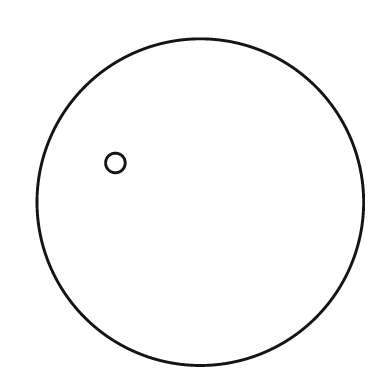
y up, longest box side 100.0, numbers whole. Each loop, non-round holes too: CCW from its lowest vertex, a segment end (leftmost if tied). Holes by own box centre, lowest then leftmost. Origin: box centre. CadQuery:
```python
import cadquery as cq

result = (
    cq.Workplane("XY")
    .moveTo(0.0, 0.0)
    .circle(50.0)
    .moveTo(-26.0, 12.0)
    .circle(3.0)
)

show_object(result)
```